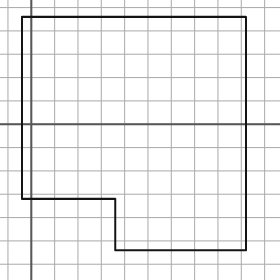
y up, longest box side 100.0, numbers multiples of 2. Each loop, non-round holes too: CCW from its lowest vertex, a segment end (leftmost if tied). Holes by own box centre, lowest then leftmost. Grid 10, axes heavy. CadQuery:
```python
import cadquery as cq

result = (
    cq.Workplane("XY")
    .moveTo(36.0, -54.0)
    .lineTo(92.0, -54.0)
    .lineTo(92.0, 46.0)
    .lineTo(-4.0, 46.0)
    .lineTo(-4.0, -32.0)
    .lineTo(36.0, -32.0)
    .close()
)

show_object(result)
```